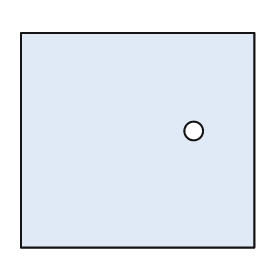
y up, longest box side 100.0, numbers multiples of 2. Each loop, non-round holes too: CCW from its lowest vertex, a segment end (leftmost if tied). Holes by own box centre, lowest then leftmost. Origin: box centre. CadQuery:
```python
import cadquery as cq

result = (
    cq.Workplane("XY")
    .moveTo(-50.0, -46.0)
    .lineTo(50.0, -46.0)
    .lineTo(50.0, 46.0)
    .lineTo(-50.0, 46.0)
    .close()
    .moveTo(24.0, 4.0)
    .circle(4.0)
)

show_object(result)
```